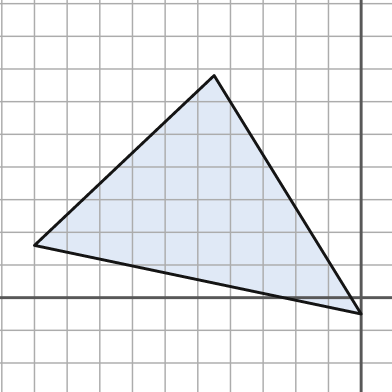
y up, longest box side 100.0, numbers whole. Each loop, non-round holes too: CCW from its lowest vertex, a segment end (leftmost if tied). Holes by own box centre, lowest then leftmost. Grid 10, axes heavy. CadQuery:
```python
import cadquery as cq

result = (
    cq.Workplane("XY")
    .moveTo(0.0, -5.0)
    .lineTo(-45.0, 68.0)
    .lineTo(-100.0, 16.0)
    .close()
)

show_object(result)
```